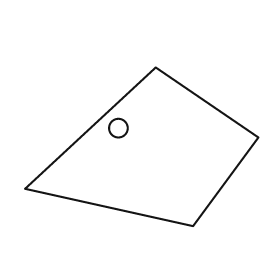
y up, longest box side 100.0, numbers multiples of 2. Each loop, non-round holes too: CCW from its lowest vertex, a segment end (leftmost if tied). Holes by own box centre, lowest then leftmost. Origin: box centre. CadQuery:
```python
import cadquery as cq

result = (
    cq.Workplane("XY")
    .moveTo(22.0, -34.0)
    .lineTo(50.0, 4.0)
    .lineTo(6.0, 34.0)
    .lineTo(-50.0, -18.0)
    .close()
    .moveTo(-10.0, 8.0)
    .circle(4.0)
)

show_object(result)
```